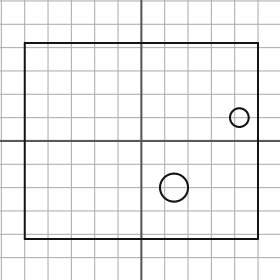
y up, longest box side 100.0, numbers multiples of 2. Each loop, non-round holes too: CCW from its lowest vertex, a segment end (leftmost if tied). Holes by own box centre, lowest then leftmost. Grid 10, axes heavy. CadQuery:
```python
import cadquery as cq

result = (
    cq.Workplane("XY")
    .moveTo(-50.0, -42.0)
    .lineTo(50.0, -42.0)
    .lineTo(50.0, 42.0)
    .lineTo(-50.0, 42.0)
    .close()
    .moveTo(14.0, -20.0)
    .circle(6.0)
    .moveTo(42.0, 10.0)
    .circle(4.0)
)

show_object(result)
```